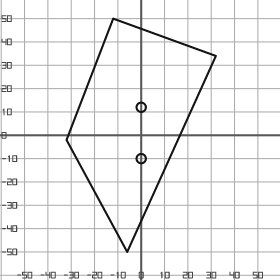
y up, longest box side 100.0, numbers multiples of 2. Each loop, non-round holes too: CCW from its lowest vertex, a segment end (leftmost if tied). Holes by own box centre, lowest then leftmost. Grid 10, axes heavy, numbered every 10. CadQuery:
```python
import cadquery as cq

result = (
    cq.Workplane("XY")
    .moveTo(-6.0, -50.0)
    .lineTo(32.0, 34.0)
    .lineTo(-12.0, 50.0)
    .lineTo(-32.0, -2.0)
    .close()
    .moveTo(0.0, -10.0)
    .circle(2.0)
    .moveTo(0.0, 12.0)
    .circle(2.0)
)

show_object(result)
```